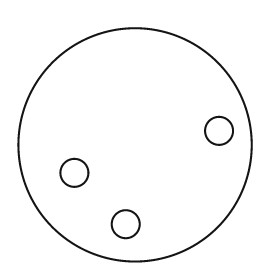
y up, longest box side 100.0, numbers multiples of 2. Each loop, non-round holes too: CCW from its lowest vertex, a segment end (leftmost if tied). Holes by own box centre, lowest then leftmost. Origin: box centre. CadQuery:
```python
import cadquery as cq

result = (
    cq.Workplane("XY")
    .moveTo(0.0, 0.0)
    .circle(50.0)
    .moveTo(-4.0, -34.0)
    .circle(6.0)
    .moveTo(-26.0, -12.0)
    .circle(6.0)
    .moveTo(36.0, 6.0)
    .circle(6.0)
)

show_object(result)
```